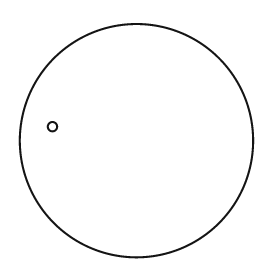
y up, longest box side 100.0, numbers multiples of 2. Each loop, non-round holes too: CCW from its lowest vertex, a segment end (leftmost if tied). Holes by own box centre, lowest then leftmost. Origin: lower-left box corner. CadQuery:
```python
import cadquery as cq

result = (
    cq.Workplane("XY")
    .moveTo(50.0, 50.0)
    .circle(50.0)
    .moveTo(14.0, 56.0)
    .circle(2.0)
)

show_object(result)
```